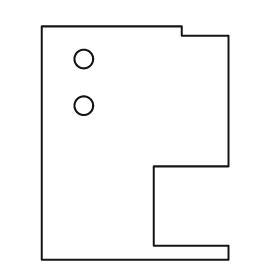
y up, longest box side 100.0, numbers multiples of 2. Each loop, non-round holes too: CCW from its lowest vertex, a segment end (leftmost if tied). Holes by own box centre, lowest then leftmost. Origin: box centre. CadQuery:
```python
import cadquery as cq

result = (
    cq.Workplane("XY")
    .moveTo(-40.0, -50.0)
    .lineTo(40.0, -50.0)
    .lineTo(40.0, -44.0)
    .lineTo(8.0, -44.0)
    .lineTo(8.0, -10.0)
    .lineTo(40.0, -10.0)
    .lineTo(40.0, 46.0)
    .lineTo(20.0, 46.0)
    .lineTo(20.0, 50.0)
    .lineTo(-40.0, 50.0)
    .close()
    .moveTo(-22.0, 16.0)
    .circle(4.0)
    .moveTo(-22.0, 36.0)
    .circle(4.0)
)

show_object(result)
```